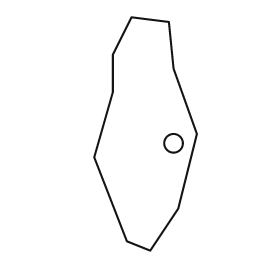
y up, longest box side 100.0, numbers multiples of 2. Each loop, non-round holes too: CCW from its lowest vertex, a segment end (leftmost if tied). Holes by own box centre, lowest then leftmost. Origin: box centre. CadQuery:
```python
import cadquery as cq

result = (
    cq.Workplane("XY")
    .moveTo(2.0, -50.0)
    .lineTo(14.0, -32.0)
    .lineTo(22.0, 0.0)
    .lineTo(12.0, 28.0)
    .lineTo(10.0, 48.0)
    .lineTo(-6.0, 50.0)
    .lineTo(-14.0, 34.0)
    .lineTo(-14.0, 18.0)
    .lineTo(-22.0, -10.0)
    .lineTo(-8.0, -46.0)
    .close()
    .moveTo(12.0, -4.0)
    .circle(4.0)
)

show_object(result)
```